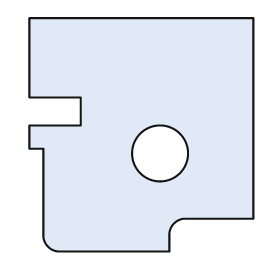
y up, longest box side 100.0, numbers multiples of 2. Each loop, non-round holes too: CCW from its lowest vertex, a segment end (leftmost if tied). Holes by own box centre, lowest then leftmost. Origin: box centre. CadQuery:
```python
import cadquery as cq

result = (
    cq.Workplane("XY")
    .moveTo(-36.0, -50.0)
    .lineTo(12.0, -50.0)
    .lineTo(12.0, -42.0)
    .threePointArc((14.0, -38.0), (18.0, -36.0))
    .lineTo(48.0, -36.0)
    .lineTo(48.0, 50.0)
    .lineTo(-48.0, 50.0)
    .lineTo(-48.0, 16.0)
    .lineTo(-26.0, 16.0)
    .lineTo(-26.0, 4.0)
    .lineTo(-48.0, 4.0)
    .lineTo(-48.0, -6.0)
    .lineTo(-42.0, -6.0)
    .lineTo(-42.0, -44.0)
    .threePointArc((-40.0, -48.0), (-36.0, -50.0))
    .close()
    .moveTo(8.0, -8.0)
    .circle(12.0)
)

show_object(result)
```